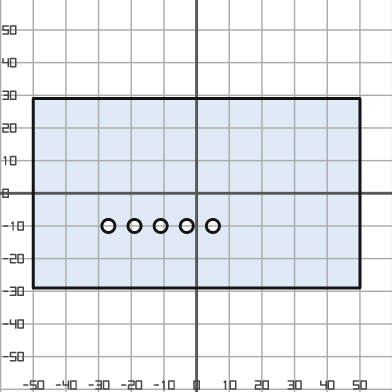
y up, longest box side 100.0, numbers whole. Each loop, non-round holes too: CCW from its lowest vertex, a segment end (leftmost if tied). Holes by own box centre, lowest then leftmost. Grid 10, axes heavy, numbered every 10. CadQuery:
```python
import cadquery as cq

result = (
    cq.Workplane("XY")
    .moveTo(-50.0, -29.0)
    .lineTo(50.0, -29.0)
    .lineTo(50.0, 29.0)
    .lineTo(-50.0, 29.0)
    .close()
    .moveTo(-27.0, -10.0)
    .circle(2.0)
    .moveTo(-19.0, -10.0)
    .circle(2.0)
    .moveTo(-11.0, -10.0)
    .circle(2.0)
    .moveTo(-3.0, -10.0)
    .circle(2.0)
    .moveTo(5.0, -10.0)
    .circle(2.0)
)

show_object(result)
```